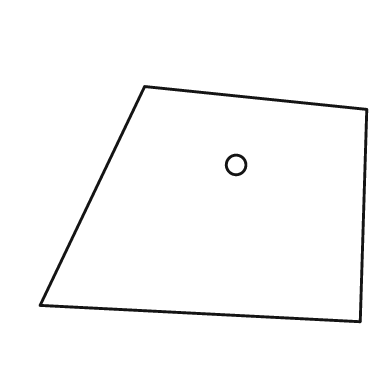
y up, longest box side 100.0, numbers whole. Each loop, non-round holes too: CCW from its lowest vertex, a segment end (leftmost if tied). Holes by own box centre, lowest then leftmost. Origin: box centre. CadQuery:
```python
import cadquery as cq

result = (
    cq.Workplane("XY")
    .moveTo(48.0, -36.0)
    .lineTo(50.0, 29.0)
    .lineTo(-18.0, 36.0)
    .lineTo(-50.0, -31.0)
    .close()
    .moveTo(10.0, 12.0)
    .circle(3.0)
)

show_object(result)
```